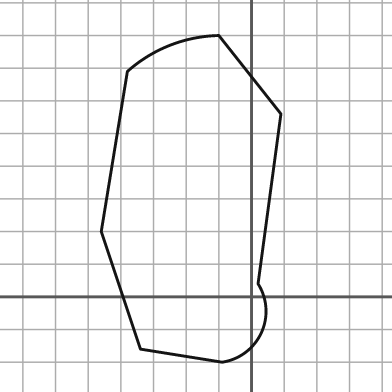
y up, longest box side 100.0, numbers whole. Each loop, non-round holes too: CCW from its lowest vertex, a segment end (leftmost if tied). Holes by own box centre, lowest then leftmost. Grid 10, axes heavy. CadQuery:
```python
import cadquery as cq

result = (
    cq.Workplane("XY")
    .moveTo(-9.0, -20.0)
    .threePointArc((3.0, -11.0), (2.0, 4.0))
    .lineTo(9.0, 56.0)
    .lineTo(-10.0, 80.0)
    .threePointArc((-25.0, 77.0), (-38.0, 69.0))
    .lineTo(-46.0, 20.0)
    .lineTo(-34.0, -16.0)
    .close()
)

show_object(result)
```